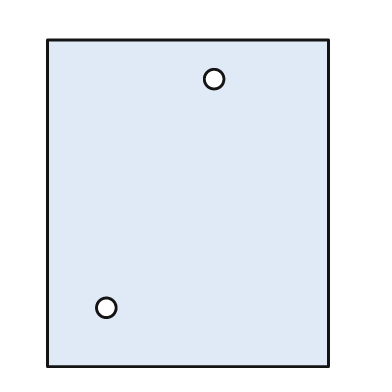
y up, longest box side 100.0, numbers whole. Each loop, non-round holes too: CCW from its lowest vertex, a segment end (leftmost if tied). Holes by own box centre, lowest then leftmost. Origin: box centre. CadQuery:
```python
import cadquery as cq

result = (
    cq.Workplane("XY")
    .moveTo(-43.0, -50.0)
    .lineTo(43.0, -50.0)
    .lineTo(43.0, 50.0)
    .lineTo(-43.0, 50.0)
    .close()
    .moveTo(-25.0, -32.0)
    .circle(3.0)
    .moveTo(8.0, 38.0)
    .circle(3.0)
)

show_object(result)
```